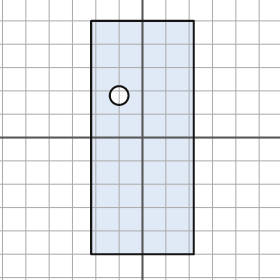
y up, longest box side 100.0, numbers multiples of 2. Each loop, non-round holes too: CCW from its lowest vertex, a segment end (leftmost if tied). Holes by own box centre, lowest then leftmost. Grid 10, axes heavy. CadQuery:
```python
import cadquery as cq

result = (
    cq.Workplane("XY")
    .moveTo(-22.0, -50.0)
    .lineTo(22.0, -50.0)
    .lineTo(22.0, 50.0)
    .lineTo(-22.0, 50.0)
    .close()
    .moveTo(-10.0, 18.0)
    .circle(4.0)
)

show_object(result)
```